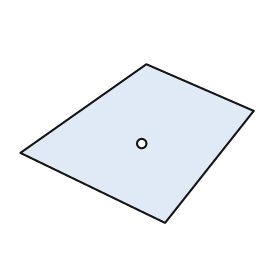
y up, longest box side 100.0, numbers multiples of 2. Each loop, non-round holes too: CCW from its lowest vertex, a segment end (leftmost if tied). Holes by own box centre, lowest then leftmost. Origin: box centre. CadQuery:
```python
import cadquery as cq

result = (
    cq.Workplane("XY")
    .moveTo(12.0, -34.0)
    .lineTo(50.0, 14.0)
    .lineTo(4.0, 34.0)
    .lineTo(-50.0, -4.0)
    .close()
    .moveTo(2.0, 0.0)
    .circle(2.0)
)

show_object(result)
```